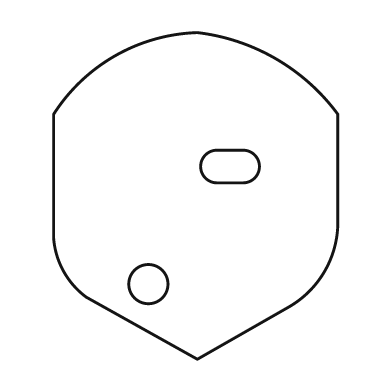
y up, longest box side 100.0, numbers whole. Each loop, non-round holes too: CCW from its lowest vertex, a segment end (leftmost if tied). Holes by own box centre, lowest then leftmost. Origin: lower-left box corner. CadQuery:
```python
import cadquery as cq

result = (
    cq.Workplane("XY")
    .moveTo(44.0, 0.0)
    .lineTo(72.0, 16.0)
    .threePointArc((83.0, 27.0), (87.0, 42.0))
    .lineTo(87.0, 75.0)
    .threePointArc((68.0, 92.0), (44.0, 100.0))
    .threePointArc((19.0, 93.0), (0.0, 75.0))
    .lineTo(0.0, 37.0)
    .threePointArc((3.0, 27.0), (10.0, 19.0))
    .close()
    .moveTo(29.0, 23.0)
    .circle(6.0)
    .moveTo(50.0, 54.0)
    .lineTo(58.0, 54.0)
    .threePointArc((63.0, 59.0), (58.0, 64.0))
    .lineTo(50.0, 64.0)
    .threePointArc((45.0, 59.0), (50.0, 54.0))
    .close()
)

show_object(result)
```